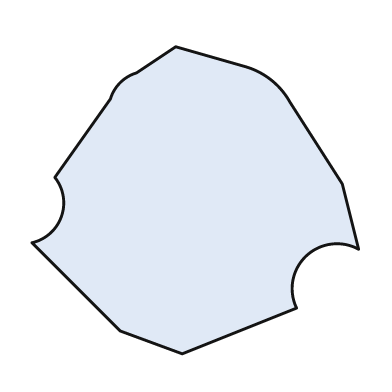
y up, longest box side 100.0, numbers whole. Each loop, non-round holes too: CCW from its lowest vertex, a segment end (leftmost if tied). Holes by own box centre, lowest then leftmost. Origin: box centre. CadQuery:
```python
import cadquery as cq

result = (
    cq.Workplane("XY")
    .moveTo(-4.0, -47.0)
    .lineTo(31.0, -33.0)
    .threePointArc((34.0, -17.0), (50.0, -15.0))
    .lineTo(45.0, 5.0)
    .lineTo(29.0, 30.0)
    .threePointArc((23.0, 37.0), (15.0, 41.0))
    .lineTo(-6.0, 47.0)
    .lineTo(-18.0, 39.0)
    .threePointArc((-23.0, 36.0), (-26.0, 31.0))
    .lineTo(-43.0, 7.0)
    .threePointArc((-41.0, -5.0), (-50.0, -13.0))
    .lineTo(-23.0, -40.0)
    .close()
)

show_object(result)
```